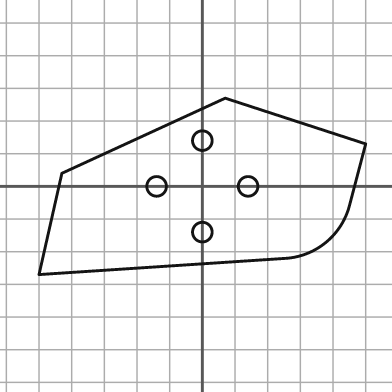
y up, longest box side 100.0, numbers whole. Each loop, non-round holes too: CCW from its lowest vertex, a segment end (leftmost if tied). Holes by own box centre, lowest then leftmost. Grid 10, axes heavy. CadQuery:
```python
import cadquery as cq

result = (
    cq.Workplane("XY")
    .moveTo(-50.0, -27.0)
    .lineTo(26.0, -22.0)
    .threePointArc((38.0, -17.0), (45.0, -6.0))
    .lineTo(50.0, 13.0)
    .lineTo(7.0, 27.0)
    .lineTo(-43.0, 4.0)
    .close()
    .moveTo(0.0, -14.0)
    .circle(3.0)
    .moveTo(-14.0, 0.0)
    .circle(3.0)
    .moveTo(14.0, 0.0)
    .circle(3.0)
    .moveTo(0.0, 14.0)
    .circle(3.0)
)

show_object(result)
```